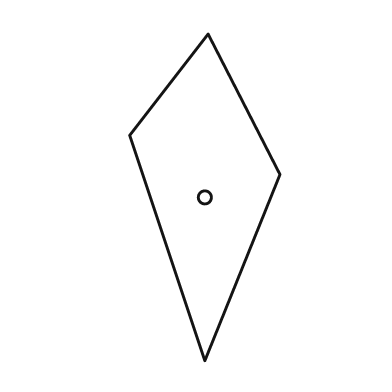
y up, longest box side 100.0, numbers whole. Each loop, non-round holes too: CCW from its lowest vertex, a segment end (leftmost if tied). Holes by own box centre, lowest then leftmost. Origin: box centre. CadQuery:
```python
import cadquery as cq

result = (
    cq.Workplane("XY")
    .moveTo(0.0, -50.0)
    .lineTo(23.0, 7.0)
    .lineTo(1.0, 50.0)
    .lineTo(-23.0, 19.0)
    .close()
    .moveTo(0.0, 0.0)
    .circle(2.0)
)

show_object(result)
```